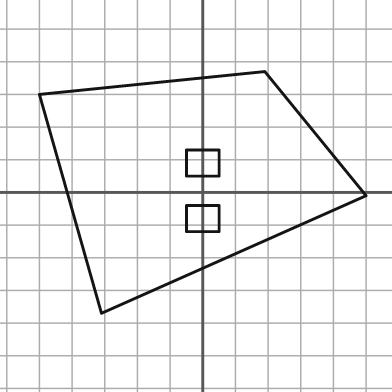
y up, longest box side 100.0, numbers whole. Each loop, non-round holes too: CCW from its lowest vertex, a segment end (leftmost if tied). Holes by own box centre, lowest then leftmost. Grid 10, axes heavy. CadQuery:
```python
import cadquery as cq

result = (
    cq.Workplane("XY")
    .moveTo(-31.0, -37.0)
    .lineTo(50.0, -1.0)
    .lineTo(19.0, 37.0)
    .lineTo(-50.0, 30.0)
    .close()
    .moveTo(-5.0, -12.0)
    .lineTo(5.0, -12.0)
    .lineTo(5.0, -4.0)
    .lineTo(-5.0, -4.0)
    .close()
    .moveTo(-5.0, 5.0)
    .lineTo(5.0, 5.0)
    .lineTo(5.0, 13.0)
    .lineTo(-5.0, 13.0)
    .close()
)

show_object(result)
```